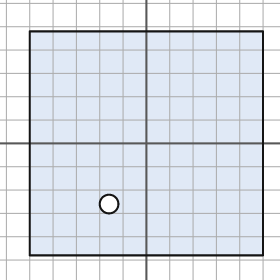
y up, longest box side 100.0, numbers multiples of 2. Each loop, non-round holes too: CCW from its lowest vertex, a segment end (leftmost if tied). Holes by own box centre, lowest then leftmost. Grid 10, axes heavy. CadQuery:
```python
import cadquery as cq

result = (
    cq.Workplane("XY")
    .moveTo(-50.0, -48.0)
    .lineTo(50.0, -48.0)
    .lineTo(50.0, 48.0)
    .lineTo(-50.0, 48.0)
    .close()
    .moveTo(-16.0, -26.0)
    .circle(4.0)
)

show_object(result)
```